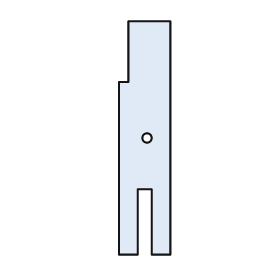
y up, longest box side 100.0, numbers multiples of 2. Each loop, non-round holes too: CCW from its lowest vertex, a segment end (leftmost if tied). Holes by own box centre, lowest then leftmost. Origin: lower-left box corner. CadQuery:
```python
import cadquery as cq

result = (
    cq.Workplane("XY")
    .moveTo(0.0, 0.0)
    .lineTo(8.0, 0.0)
    .lineTo(8.0, 28.0)
    .lineTo(14.0, 28.0)
    .lineTo(14.0, 0.0)
    .lineTo(22.0, 0.0)
    .lineTo(22.0, 100.0)
    .lineTo(4.0, 100.0)
    .lineTo(4.0, 74.0)
    .lineTo(0.0, 74.0)
    .close()
    .moveTo(12.0, 50.0)
    .circle(2.0)
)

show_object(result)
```